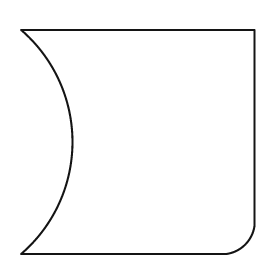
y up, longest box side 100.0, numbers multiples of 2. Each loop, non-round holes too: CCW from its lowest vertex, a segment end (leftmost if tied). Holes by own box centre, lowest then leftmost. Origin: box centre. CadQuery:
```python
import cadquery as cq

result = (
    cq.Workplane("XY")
    .moveTo(-50.0, -48.0)
    .lineTo(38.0, -48.0)
    .threePointArc((46.0, -44.0), (50.0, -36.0))
    .lineTo(50.0, 48.0)
    .lineTo(-50.0, 48.0)
    .threePointArc((-28.0, 0.0), (-50.0, -48.0))
    .close()
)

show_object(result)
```